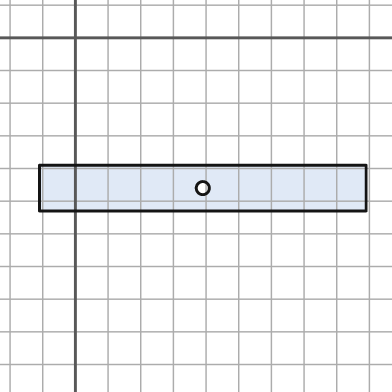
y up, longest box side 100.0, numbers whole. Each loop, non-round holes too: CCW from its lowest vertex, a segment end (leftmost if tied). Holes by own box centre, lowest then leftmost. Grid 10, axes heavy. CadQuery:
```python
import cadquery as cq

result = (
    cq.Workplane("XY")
    .moveTo(-11.0, -53.0)
    .lineTo(89.0, -53.0)
    .lineTo(89.0, -39.0)
    .lineTo(-11.0, -39.0)
    .close()
    .moveTo(39.0, -46.0)
    .circle(2.0)
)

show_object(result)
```